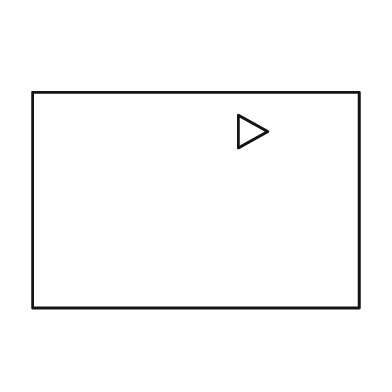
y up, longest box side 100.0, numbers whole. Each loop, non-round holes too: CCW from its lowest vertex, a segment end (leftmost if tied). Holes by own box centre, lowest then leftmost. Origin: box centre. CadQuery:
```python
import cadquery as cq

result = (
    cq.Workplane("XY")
    .moveTo(-50.0, -33.0)
    .lineTo(50.0, -33.0)
    .lineTo(50.0, 33.0)
    .lineTo(-50.0, 33.0)
    .close()
    .moveTo(13.0, 16.0)
    .lineTo(22.0, 21.0)
    .lineTo(13.0, 26.0)
    .close()
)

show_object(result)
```